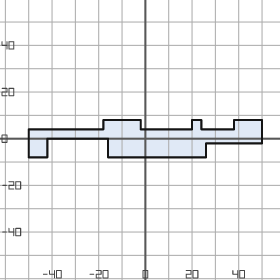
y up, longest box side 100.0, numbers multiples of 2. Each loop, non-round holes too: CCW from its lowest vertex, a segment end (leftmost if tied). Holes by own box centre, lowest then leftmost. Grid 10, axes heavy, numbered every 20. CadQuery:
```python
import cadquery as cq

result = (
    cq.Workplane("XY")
    .moveTo(-50.0, -8.0)
    .lineTo(-42.0, -8.0)
    .lineTo(-42.0, 0.0)
    .lineTo(-16.0, 0.0)
    .lineTo(-16.0, -8.0)
    .lineTo(26.0, -8.0)
    .lineTo(26.0, -2.0)
    .lineTo(50.0, -2.0)
    .lineTo(50.0, 8.0)
    .lineTo(38.0, 8.0)
    .lineTo(38.0, 4.0)
    .lineTo(24.0, 4.0)
    .lineTo(24.0, 8.0)
    .lineTo(20.0, 8.0)
    .lineTo(20.0, 4.0)
    .lineTo(-2.0, 4.0)
    .lineTo(-2.0, 8.0)
    .lineTo(-18.0, 8.0)
    .lineTo(-18.0, 4.0)
    .lineTo(-50.0, 4.0)
    .close()
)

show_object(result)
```